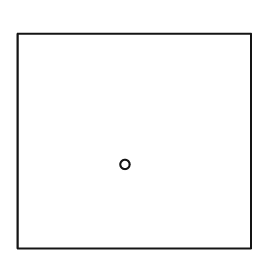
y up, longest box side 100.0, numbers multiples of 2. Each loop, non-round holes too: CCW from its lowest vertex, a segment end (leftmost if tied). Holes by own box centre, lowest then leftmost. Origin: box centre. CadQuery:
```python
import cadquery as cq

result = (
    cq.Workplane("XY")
    .moveTo(-50.0, -46.0)
    .lineTo(50.0, -46.0)
    .lineTo(50.0, 46.0)
    .lineTo(-50.0, 46.0)
    .close()
    .moveTo(-4.0, -10.0)
    .circle(2.0)
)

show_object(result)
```